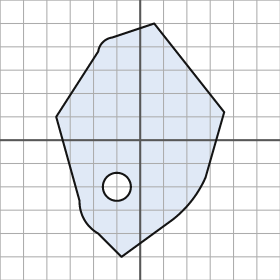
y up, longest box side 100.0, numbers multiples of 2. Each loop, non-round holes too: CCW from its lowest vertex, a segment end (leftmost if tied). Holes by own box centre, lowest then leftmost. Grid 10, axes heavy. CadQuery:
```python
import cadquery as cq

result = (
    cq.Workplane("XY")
    .moveTo(-8.0, -50.0)
    .lineTo(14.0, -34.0)
    .threePointArc((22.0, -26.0), (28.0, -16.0))
    .lineTo(36.0, 12.0)
    .lineTo(6.0, 50.0)
    .lineTo(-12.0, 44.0)
    .threePointArc((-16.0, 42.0), (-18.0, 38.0))
    .lineTo(-36.0, 10.0)
    .lineTo(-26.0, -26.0)
    .threePointArc((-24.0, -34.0), (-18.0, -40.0))
    .close()
    .moveTo(-10.0, -20.0)
    .circle(6.0)
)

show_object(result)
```